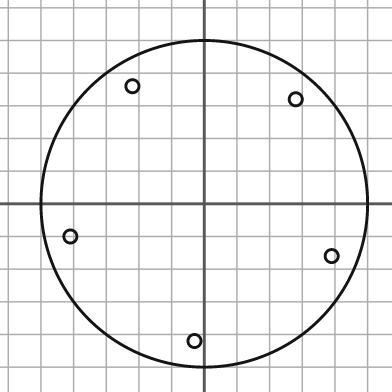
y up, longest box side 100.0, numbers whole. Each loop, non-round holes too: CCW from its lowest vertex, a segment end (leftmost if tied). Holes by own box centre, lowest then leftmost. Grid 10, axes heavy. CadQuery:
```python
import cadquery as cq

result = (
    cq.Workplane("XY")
    .moveTo(0.0, 0.0)
    .circle(50.0)
    .moveTo(-3.0, -42.0)
    .circle(2.0)
    .moveTo(39.0, -16.0)
    .circle(2.0)
    .moveTo(-41.0, -10.0)
    .circle(2.0)
    .moveTo(28.0, 32.0)
    .circle(2.0)
    .moveTo(-22.0, 36.0)
    .circle(2.0)
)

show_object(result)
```